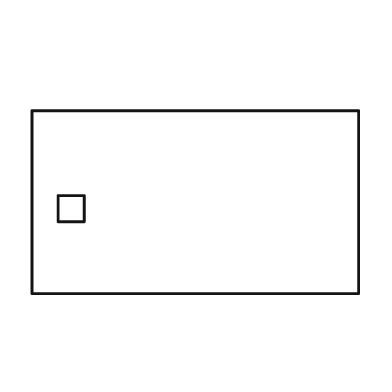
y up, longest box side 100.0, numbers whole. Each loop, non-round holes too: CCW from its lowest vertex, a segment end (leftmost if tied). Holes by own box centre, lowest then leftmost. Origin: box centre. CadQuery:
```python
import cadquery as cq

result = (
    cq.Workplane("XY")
    .moveTo(-50.0, -28.0)
    .lineTo(50.0, -28.0)
    .lineTo(50.0, 28.0)
    .lineTo(-50.0, 28.0)
    .close()
    .moveTo(-42.0, -6.0)
    .lineTo(-34.0, -6.0)
    .lineTo(-34.0, 2.0)
    .lineTo(-42.0, 2.0)
    .close()
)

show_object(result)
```